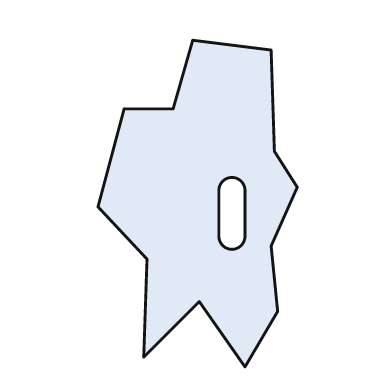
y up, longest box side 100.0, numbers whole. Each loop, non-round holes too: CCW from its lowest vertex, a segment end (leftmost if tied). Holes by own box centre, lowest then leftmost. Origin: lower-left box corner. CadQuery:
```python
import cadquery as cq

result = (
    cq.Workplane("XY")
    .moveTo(45.0, 0.0)
    .lineTo(55.0, 17.0)
    .lineTo(53.0, 37.0)
    .lineTo(61.0, 55.0)
    .lineTo(54.0, 66.0)
    .lineTo(53.0, 97.0)
    .lineTo(29.0, 100.0)
    .lineTo(23.0, 79.0)
    .lineTo(8.0, 79.0)
    .lineTo(0.0, 49.0)
    .lineTo(15.0, 33.0)
    .lineTo(14.0, 3.0)
    .lineTo(31.0, 20.0)
    .close()
    .moveTo(37.0, 40.0)
    .threePointArc((41.0, 36.0), (45.0, 40.0))
    .lineTo(45.0, 54.0)
    .threePointArc((41.0, 58.0), (37.0, 54.0))
    .close()
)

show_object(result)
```